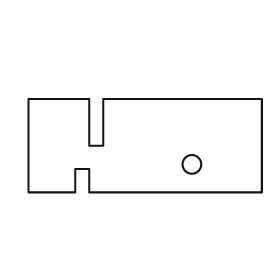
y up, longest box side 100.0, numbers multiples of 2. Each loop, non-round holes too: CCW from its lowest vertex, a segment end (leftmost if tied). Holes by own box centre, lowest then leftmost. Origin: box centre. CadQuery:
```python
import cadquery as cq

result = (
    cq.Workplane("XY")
    .moveTo(-50.0, -20.0)
    .lineTo(-30.0, -20.0)
    .lineTo(-30.0, -10.0)
    .lineTo(-24.0, -10.0)
    .lineTo(-24.0, -20.0)
    .lineTo(50.0, -20.0)
    .lineTo(50.0, 20.0)
    .lineTo(-18.0, 20.0)
    .lineTo(-18.0, 0.0)
    .lineTo(-24.0, 0.0)
    .lineTo(-24.0, 20.0)
    .lineTo(-50.0, 20.0)
    .close()
    .moveTo(20.0, -8.0)
    .circle(4.0)
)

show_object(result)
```